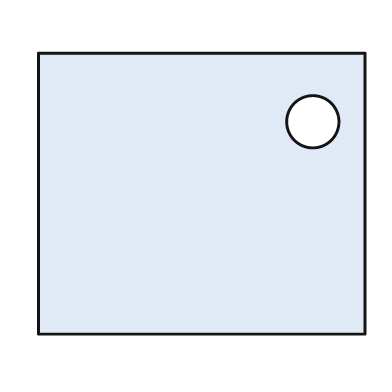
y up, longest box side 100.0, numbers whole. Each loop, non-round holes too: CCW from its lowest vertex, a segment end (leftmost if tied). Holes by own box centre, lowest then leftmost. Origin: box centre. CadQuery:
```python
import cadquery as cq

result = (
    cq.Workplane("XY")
    .moveTo(-50.0, -43.0)
    .lineTo(50.0, -43.0)
    .lineTo(50.0, 43.0)
    .lineTo(-50.0, 43.0)
    .close()
    .moveTo(34.0, 22.0)
    .circle(8.0)
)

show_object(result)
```